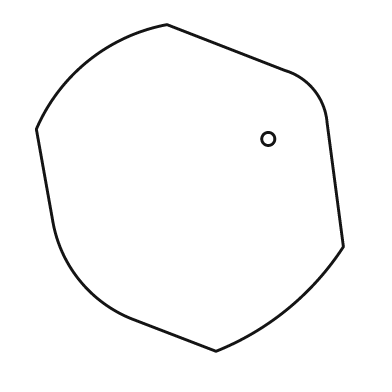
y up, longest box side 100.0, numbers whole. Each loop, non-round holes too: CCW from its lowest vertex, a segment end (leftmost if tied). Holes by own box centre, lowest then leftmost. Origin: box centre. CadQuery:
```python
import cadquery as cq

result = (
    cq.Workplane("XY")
    .moveTo(8.0, -50.0)
    .threePointArc((30.0, -37.0), (47.0, -18.0))
    .lineTo(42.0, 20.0)
    .threePointArc((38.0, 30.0), (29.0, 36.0))
    .lineTo(-7.0, 50.0)
    .threePointArc((-31.0, 39.0), (-47.0, 18.0))
    .lineTo(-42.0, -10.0)
    .threePointArc((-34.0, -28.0), (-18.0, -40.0))
    .close()
    .moveTo(24.0, 15.0)
    .circle(2.0)
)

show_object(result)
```